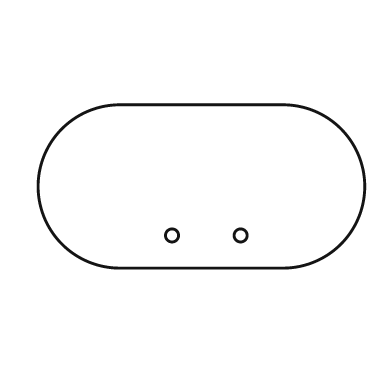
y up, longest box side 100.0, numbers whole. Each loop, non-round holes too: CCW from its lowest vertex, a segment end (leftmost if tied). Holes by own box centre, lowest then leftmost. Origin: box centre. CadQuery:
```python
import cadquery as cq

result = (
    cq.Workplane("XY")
    .moveTo(-25.0, -25.0)
    .lineTo(25.0, -25.0)
    .threePointArc((50.0, 0.0), (25.0, 25.0))
    .lineTo(-25.0, 25.0)
    .threePointArc((-50.0, 0.0), (-25.0, -25.0))
    .close()
    .moveTo(-9.0, -15.0)
    .circle(2.0)
    .moveTo(12.0, -15.0)
    .circle(2.0)
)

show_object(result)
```